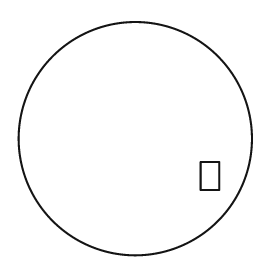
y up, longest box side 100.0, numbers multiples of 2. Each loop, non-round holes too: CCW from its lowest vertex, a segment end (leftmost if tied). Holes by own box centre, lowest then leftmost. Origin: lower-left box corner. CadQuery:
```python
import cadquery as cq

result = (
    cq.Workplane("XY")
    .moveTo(50.0, 50.0)
    .circle(50.0)
    .moveTo(78.0, 28.0)
    .lineTo(86.0, 28.0)
    .lineTo(86.0, 40.0)
    .lineTo(78.0, 40.0)
    .close()
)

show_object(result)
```